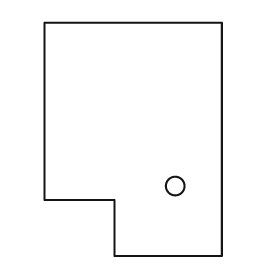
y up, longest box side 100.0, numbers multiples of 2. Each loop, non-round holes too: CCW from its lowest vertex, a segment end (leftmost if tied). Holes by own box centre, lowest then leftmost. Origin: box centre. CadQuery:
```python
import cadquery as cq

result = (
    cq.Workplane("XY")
    .moveTo(-8.0, -50.0)
    .lineTo(38.0, -50.0)
    .lineTo(38.0, 50.0)
    .lineTo(-38.0, 50.0)
    .lineTo(-38.0, -26.0)
    .lineTo(-8.0, -26.0)
    .close()
    .moveTo(18.0, -20.0)
    .circle(4.0)
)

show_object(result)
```